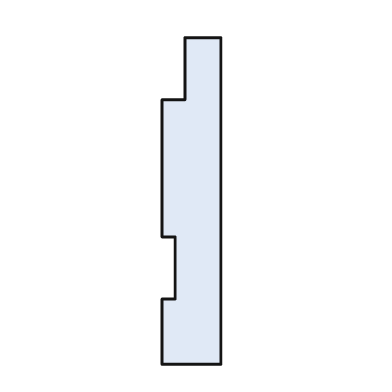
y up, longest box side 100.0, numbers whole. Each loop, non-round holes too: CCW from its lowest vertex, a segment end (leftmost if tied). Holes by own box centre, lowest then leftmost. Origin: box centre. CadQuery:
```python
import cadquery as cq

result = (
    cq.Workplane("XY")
    .moveTo(-9.0, -50.0)
    .lineTo(9.0, -50.0)
    .lineTo(9.0, 50.0)
    .lineTo(-2.0, 50.0)
    .lineTo(-2.0, 31.0)
    .lineTo(-9.0, 31.0)
    .lineTo(-9.0, -11.0)
    .lineTo(-5.0, -11.0)
    .lineTo(-5.0, -30.0)
    .lineTo(-9.0, -30.0)
    .close()
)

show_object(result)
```